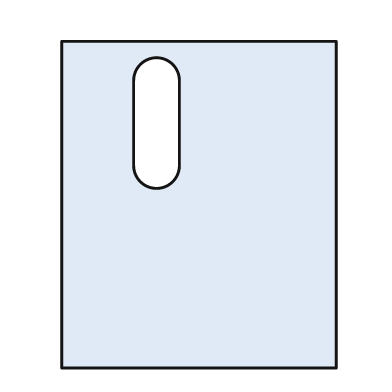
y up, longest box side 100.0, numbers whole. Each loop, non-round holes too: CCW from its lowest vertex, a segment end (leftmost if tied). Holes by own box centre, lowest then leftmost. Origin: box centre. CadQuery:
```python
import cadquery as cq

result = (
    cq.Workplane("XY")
    .moveTo(-42.0, -50.0)
    .lineTo(42.0, -50.0)
    .lineTo(42.0, 50.0)
    .lineTo(-42.0, 50.0)
    .close()
    .moveTo(-20.0, 12.0)
    .threePointArc((-13.0, 5.0), (-6.0, 12.0))
    .lineTo(-6.0, 38.0)
    .threePointArc((-13.0, 45.0), (-20.0, 38.0))
    .close()
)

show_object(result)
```